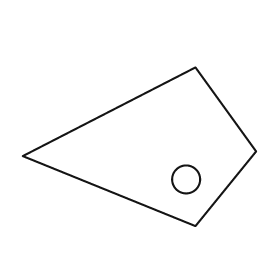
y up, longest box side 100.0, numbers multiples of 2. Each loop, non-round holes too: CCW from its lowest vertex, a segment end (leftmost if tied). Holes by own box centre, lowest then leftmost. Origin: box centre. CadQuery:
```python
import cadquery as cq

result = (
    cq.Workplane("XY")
    .moveTo(24.0, -34.0)
    .lineTo(50.0, -2.0)
    .lineTo(24.0, 34.0)
    .lineTo(-50.0, -4.0)
    .close()
    .moveTo(20.0, -14.0)
    .circle(6.0)
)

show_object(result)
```